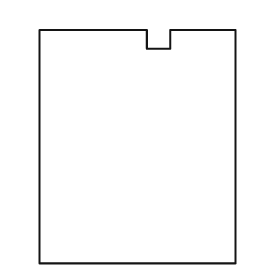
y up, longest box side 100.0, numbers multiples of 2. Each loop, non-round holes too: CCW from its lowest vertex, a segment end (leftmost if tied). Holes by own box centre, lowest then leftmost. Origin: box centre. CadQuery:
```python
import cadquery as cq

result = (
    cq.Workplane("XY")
    .moveTo(-42.0, -50.0)
    .lineTo(42.0, -50.0)
    .lineTo(42.0, 50.0)
    .lineTo(14.0, 50.0)
    .lineTo(14.0, 42.0)
    .lineTo(4.0, 42.0)
    .lineTo(4.0, 50.0)
    .lineTo(-42.0, 50.0)
    .close()
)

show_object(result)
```